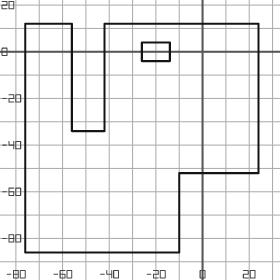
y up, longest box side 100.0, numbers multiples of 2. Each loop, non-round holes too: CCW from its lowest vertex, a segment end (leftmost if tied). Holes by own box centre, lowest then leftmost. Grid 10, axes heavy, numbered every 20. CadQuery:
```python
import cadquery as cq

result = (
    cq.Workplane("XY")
    .moveTo(-76.0, -86.0)
    .lineTo(-10.0, -86.0)
    .lineTo(-10.0, -52.0)
    .lineTo(24.0, -52.0)
    .lineTo(24.0, 12.0)
    .lineTo(-42.0, 12.0)
    .lineTo(-42.0, -34.0)
    .lineTo(-56.0, -34.0)
    .lineTo(-56.0, 12.0)
    .lineTo(-76.0, 12.0)
    .close()
    .moveTo(-26.0, -4.0)
    .lineTo(-14.0, -4.0)
    .lineTo(-14.0, 4.0)
    .lineTo(-26.0, 4.0)
    .close()
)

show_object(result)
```